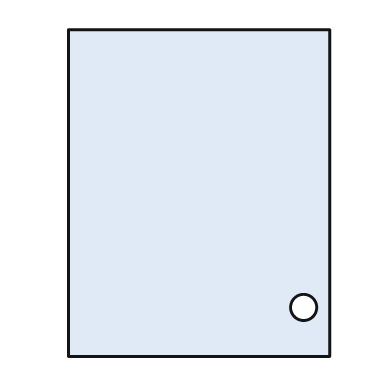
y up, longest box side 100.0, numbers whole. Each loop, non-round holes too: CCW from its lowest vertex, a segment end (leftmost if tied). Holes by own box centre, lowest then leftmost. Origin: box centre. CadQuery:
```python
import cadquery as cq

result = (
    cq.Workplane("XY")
    .moveTo(-40.0, -50.0)
    .lineTo(40.0, -50.0)
    .lineTo(40.0, 50.0)
    .lineTo(-40.0, 50.0)
    .close()
    .moveTo(32.0, -35.0)
    .circle(4.0)
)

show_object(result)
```